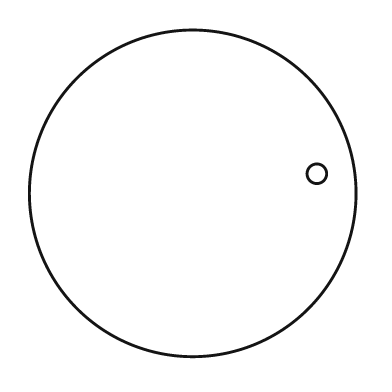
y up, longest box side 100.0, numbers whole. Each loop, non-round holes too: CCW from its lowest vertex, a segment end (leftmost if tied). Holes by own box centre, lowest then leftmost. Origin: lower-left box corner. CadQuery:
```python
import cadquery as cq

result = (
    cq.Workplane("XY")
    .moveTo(50.0, 50.0)
    .circle(50.0)
    .moveTo(88.0, 56.0)
    .circle(3.0)
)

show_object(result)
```